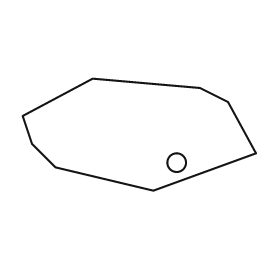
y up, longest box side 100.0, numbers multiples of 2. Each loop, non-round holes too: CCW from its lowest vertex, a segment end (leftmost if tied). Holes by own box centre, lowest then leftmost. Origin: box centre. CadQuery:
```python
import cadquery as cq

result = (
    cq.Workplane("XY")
    .moveTo(6.0, -24.0)
    .lineTo(50.0, -8.0)
    .lineTo(38.0, 14.0)
    .lineTo(26.0, 20.0)
    .lineTo(-20.0, 24.0)
    .lineTo(-50.0, 8.0)
    .lineTo(-46.0, -4.0)
    .lineTo(-36.0, -14.0)
    .close()
    .moveTo(16.0, -12.0)
    .circle(4.0)
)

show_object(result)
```